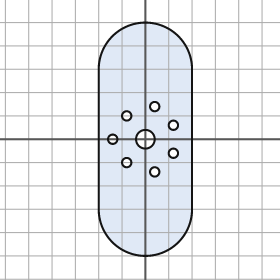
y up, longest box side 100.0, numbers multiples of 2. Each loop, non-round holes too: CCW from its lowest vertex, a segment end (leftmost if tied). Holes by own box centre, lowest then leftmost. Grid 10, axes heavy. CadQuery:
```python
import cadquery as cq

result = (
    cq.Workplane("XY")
    .moveTo(-20.0, -30.0)
    .threePointArc((0.0, -50.0), (20.0, -30.0))
    .lineTo(20.0, 30.0)
    .threePointArc((0.0, 50.0), (-20.0, 30.0))
    .close()
    .moveTo(4.0, -14.0)
    .circle(2.0)
    .moveTo(-8.0, -10.0)
    .circle(2.0)
    .moveTo(12.0, -6.0)
    .circle(2.0)
    .moveTo(-14.0, 0.0)
    .circle(2.0)
    .moveTo(0.0, 0.0)
    .circle(4.0)
    .moveTo(12.0, 6.0)
    .circle(2.0)
    .moveTo(-8.0, 10.0)
    .circle(2.0)
    .moveTo(4.0, 14.0)
    .circle(2.0)
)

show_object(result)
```